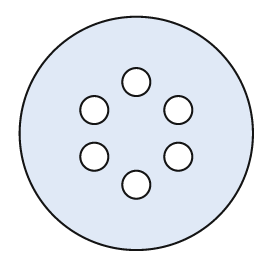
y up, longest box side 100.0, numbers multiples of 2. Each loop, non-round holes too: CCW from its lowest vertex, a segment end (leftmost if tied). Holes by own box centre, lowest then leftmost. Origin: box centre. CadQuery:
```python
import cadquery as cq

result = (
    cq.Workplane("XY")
    .moveTo(0.0, 0.0)
    .circle(50.0)
    .moveTo(0.0, -22.0)
    .circle(6.0)
    .moveTo(-18.0, -10.0)
    .circle(6.0)
    .moveTo(18.0, -10.0)
    .circle(6.0)
    .moveTo(-18.0, 10.0)
    .circle(6.0)
    .moveTo(18.0, 10.0)
    .circle(6.0)
    .moveTo(0.0, 22.0)
    .circle(6.0)
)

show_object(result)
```